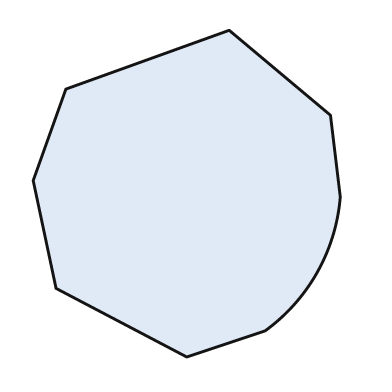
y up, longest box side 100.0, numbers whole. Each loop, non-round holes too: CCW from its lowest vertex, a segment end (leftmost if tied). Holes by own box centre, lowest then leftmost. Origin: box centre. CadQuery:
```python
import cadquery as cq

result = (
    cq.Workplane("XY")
    .moveTo(0.0, -50.0)
    .lineTo(24.0, -42.0)
    .threePointArc((40.0, -24.0), (47.0, -1.0))
    .lineTo(44.0, 24.0)
    .lineTo(13.0, 50.0)
    .lineTo(-37.0, 32.0)
    .lineTo(-47.0, 4.0)
    .lineTo(-40.0, -29.0)
    .close()
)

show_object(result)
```